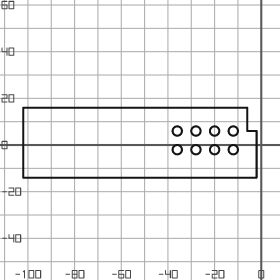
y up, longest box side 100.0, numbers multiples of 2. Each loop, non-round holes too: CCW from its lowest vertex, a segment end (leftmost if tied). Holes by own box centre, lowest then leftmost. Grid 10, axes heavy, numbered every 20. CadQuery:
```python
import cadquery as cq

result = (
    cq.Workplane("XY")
    .moveTo(-102.0, -14.0)
    .lineTo(-2.0, -14.0)
    .lineTo(-2.0, 6.0)
    .lineTo(-6.0, 6.0)
    .lineTo(-6.0, 16.0)
    .lineTo(-102.0, 16.0)
    .close()
    .moveTo(-36.0, -2.0)
    .circle(2.0)
    .moveTo(-28.0, -2.0)
    .circle(2.0)
    .moveTo(-20.0, -2.0)
    .circle(2.0)
    .moveTo(-12.0, -2.0)
    .circle(2.0)
    .moveTo(-36.0, 6.0)
    .circle(2.0)
    .moveTo(-28.0, 6.0)
    .circle(2.0)
    .moveTo(-20.0, 6.0)
    .circle(2.0)
    .moveTo(-12.0, 6.0)
    .circle(2.0)
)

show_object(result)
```